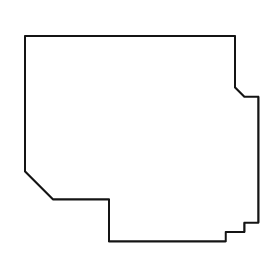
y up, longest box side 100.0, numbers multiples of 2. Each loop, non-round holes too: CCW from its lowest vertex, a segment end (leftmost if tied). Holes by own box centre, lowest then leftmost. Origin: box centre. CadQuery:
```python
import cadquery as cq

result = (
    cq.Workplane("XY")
    .moveTo(-14.0, -44.0)
    .lineTo(36.0, -44.0)
    .lineTo(36.0, -40.0)
    .lineTo(44.0, -40.0)
    .lineTo(44.0, -36.0)
    .lineTo(50.0, -36.0)
    .lineTo(50.0, 18.0)
    .lineTo(44.0, 18.0)
    .lineTo(40.0, 22.0)
    .lineTo(40.0, 44.0)
    .lineTo(-50.0, 44.0)
    .lineTo(-50.0, -14.0)
    .lineTo(-38.0, -26.0)
    .lineTo(-14.0, -26.0)
    .close()
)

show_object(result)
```